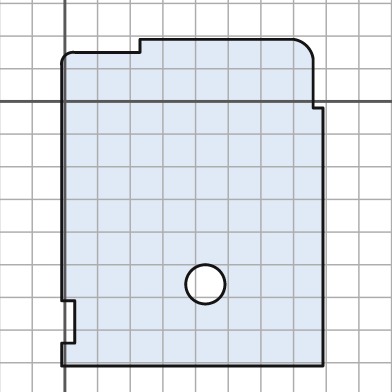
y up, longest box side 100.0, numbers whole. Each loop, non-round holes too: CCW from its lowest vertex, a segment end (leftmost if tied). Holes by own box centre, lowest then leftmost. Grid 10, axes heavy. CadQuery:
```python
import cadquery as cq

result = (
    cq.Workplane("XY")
    .moveTo(-1.0, -81.0)
    .lineTo(79.0, -81.0)
    .lineTo(79.0, -2.0)
    .lineTo(76.0, -2.0)
    .lineTo(76.0, 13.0)
    .threePointArc((74.0, 17.0), (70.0, 19.0))
    .lineTo(23.0, 19.0)
    .lineTo(23.0, 15.0)
    .lineTo(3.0, 15.0)
    .threePointArc((0.0, 14.0), (-1.0, 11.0))
    .lineTo(-1.0, -61.0)
    .lineTo(3.0, -61.0)
    .lineTo(3.0, -74.0)
    .lineTo(-1.0, -74.0)
    .close()
    .moveTo(43.0, -56.0)
    .circle(6.0)
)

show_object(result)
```